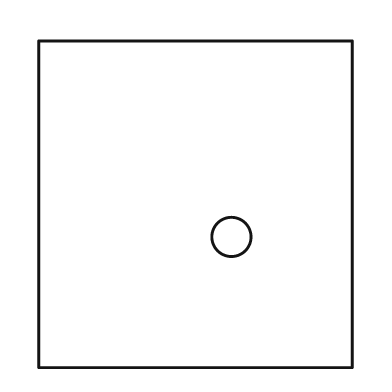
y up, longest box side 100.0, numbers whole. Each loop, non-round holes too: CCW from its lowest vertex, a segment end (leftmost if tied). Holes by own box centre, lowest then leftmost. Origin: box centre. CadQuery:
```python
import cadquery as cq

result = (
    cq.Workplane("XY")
    .moveTo(-48.0, -50.0)
    .lineTo(48.0, -50.0)
    .lineTo(48.0, 50.0)
    .lineTo(-48.0, 50.0)
    .close()
    .moveTo(11.0, -10.0)
    .circle(6.0)
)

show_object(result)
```